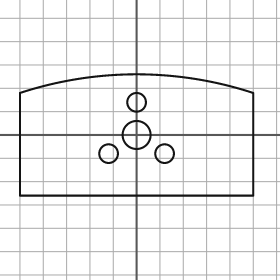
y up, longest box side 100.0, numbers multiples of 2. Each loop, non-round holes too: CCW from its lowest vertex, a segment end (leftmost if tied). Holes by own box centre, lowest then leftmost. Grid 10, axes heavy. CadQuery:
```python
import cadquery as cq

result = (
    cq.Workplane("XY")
    .moveTo(-50.0, -26.0)
    .lineTo(50.0, -26.0)
    .lineTo(50.0, 18.0)
    .threePointArc((0.0, 26.0), (-50.0, 18.0))
    .close()
    .moveTo(-12.0, -8.0)
    .circle(4.0)
    .moveTo(12.0, -8.0)
    .circle(4.0)
    .moveTo(0.0, 0.0)
    .circle(6.0)
    .moveTo(0.0, 14.0)
    .circle(4.0)
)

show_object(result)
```